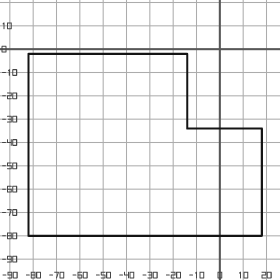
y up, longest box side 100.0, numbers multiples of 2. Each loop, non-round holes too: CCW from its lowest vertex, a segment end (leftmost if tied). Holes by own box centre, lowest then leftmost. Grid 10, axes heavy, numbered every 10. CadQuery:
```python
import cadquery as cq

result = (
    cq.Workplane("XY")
    .moveTo(-82.0, -80.0)
    .lineTo(18.0, -80.0)
    .lineTo(18.0, -34.0)
    .lineTo(-14.0, -34.0)
    .lineTo(-14.0, -2.0)
    .lineTo(-82.0, -2.0)
    .close()
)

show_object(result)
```